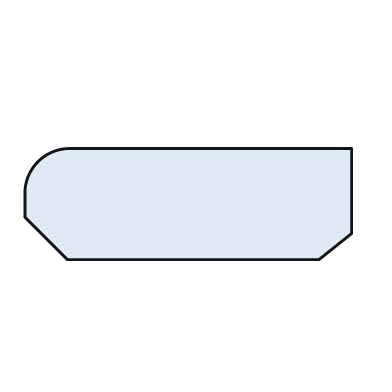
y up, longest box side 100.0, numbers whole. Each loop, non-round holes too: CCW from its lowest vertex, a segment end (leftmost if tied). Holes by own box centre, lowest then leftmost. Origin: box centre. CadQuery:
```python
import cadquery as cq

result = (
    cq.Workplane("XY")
    .moveTo(-37.0, -17.0)
    .lineTo(40.0, -17.0)
    .lineTo(50.0, -9.0)
    .lineTo(50.0, 17.0)
    .lineTo(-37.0, 17.0)
    .threePointArc((-46.0, 13.0), (-50.0, 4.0))
    .lineTo(-50.0, -4.0)
    .close()
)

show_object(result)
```